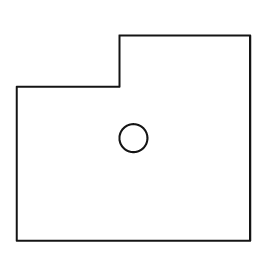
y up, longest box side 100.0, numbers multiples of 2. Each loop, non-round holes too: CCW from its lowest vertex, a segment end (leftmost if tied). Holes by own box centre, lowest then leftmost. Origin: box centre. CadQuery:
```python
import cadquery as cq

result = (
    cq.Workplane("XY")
    .moveTo(-50.0, -44.0)
    .lineTo(50.0, -44.0)
    .lineTo(50.0, 44.0)
    .lineTo(-6.0, 44.0)
    .lineTo(-6.0, 22.0)
    .lineTo(-50.0, 22.0)
    .close()
    .moveTo(0.0, 0.0)
    .circle(6.0)
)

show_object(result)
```